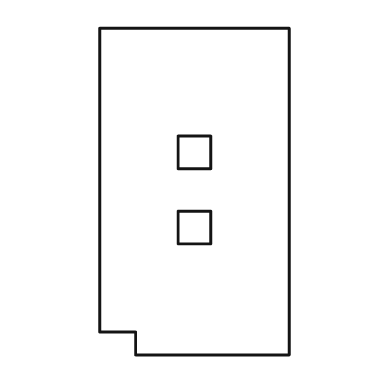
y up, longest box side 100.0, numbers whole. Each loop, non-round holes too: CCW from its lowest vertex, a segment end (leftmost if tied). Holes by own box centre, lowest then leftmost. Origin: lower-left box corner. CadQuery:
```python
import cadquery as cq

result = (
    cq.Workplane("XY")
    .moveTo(11.0, 0.0)
    .lineTo(58.0, 0.0)
    .lineTo(58.0, 100.0)
    .lineTo(0.0, 100.0)
    .lineTo(0.0, 7.0)
    .lineTo(11.0, 7.0)
    .close()
    .moveTo(24.0, 34.0)
    .lineTo(34.0, 34.0)
    .lineTo(34.0, 44.0)
    .lineTo(24.0, 44.0)
    .close()
    .moveTo(24.0, 57.0)
    .lineTo(34.0, 57.0)
    .lineTo(34.0, 67.0)
    .lineTo(24.0, 67.0)
    .close()
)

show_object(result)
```